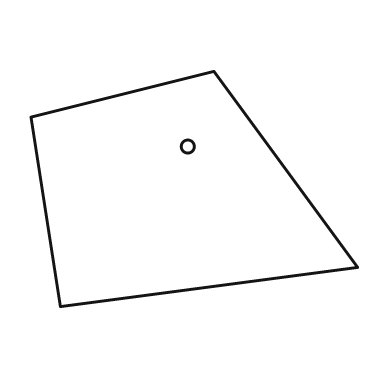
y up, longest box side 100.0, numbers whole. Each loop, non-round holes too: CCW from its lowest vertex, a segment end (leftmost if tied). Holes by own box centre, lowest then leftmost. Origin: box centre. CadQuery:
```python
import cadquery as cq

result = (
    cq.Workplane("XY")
    .moveTo(-41.0, -36.0)
    .lineTo(50.0, -24.0)
    .lineTo(6.0, 36.0)
    .lineTo(-50.0, 22.0)
    .close()
    .moveTo(-2.0, 13.0)
    .circle(2.0)
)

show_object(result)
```